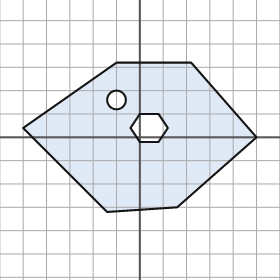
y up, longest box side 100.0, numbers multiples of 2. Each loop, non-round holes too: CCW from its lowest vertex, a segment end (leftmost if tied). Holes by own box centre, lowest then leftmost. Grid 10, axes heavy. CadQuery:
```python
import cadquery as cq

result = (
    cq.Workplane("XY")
    .moveTo(-14.0, -32.0)
    .lineTo(16.0, -30.0)
    .lineTo(50.0, 0.0)
    .lineTo(22.0, 32.0)
    .lineTo(-10.0, 32.0)
    .lineTo(-50.0, 4.0)
    .close()
    .moveTo(0.0, -2.0)
    .lineTo(8.0, -2.0)
    .lineTo(12.0, 4.0)
    .lineTo(8.0, 10.0)
    .lineTo(0.0, 10.0)
    .lineTo(-4.0, 4.0)
    .close()
    .moveTo(-10.0, 16.0)
    .circle(4.0)
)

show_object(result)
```